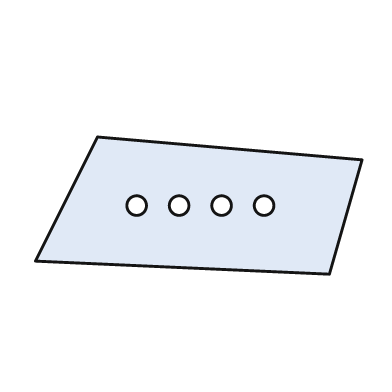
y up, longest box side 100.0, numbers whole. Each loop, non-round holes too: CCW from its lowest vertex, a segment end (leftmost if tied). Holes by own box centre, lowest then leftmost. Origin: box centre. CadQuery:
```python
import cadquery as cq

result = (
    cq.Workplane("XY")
    .moveTo(40.0, -21.0)
    .lineTo(50.0, 14.0)
    .lineTo(-31.0, 21.0)
    .lineTo(-50.0, -17.0)
    .close()
    .moveTo(-19.0, 0.0)
    .circle(3.0)
    .moveTo(-6.0, 0.0)
    .circle(3.0)
    .moveTo(7.0, 0.0)
    .circle(3.0)
    .moveTo(20.0, 0.0)
    .circle(3.0)
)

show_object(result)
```